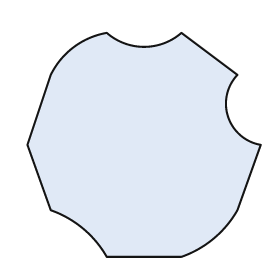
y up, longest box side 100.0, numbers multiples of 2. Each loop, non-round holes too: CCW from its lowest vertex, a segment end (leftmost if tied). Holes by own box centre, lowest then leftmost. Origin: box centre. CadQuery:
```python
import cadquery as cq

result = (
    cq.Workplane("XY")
    .moveTo(-16.0, -48.0)
    .lineTo(16.0, -48.0)
    .threePointArc((30.0, -40.0), (40.0, -28.0))
    .lineTo(50.0, 0.0)
    .threePointArc((36.0, 12.0), (40.0, 30.0))
    .lineTo(16.0, 48.0)
    .threePointArc((0.0, 42.0), (-16.0, 48.0))
    .threePointArc((-30.0, 42.0), (-40.0, 30.0))
    .lineTo(-50.0, 0.0)
    .lineTo(-40.0, -28.0)
    .threePointArc((-26.0, -36.0), (-16.0, -48.0))
    .close()
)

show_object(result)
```